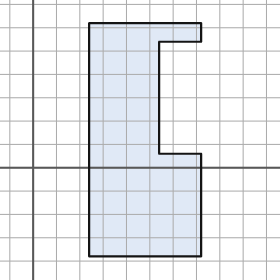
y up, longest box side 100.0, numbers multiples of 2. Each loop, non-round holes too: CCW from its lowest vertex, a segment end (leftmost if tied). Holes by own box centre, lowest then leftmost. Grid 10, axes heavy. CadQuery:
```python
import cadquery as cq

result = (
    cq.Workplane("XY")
    .moveTo(24.0, -38.0)
    .lineTo(72.0, -38.0)
    .lineTo(72.0, 6.0)
    .lineTo(54.0, 6.0)
    .lineTo(54.0, 54.0)
    .lineTo(72.0, 54.0)
    .lineTo(72.0, 62.0)
    .lineTo(24.0, 62.0)
    .close()
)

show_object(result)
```